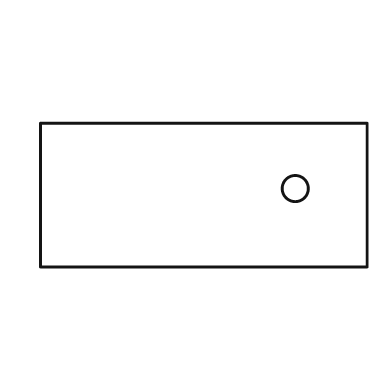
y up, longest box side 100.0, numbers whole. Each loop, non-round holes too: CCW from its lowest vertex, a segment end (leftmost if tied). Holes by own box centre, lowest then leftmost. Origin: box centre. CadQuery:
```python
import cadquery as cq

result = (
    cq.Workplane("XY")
    .moveTo(-50.0, -22.0)
    .lineTo(50.0, -22.0)
    .lineTo(50.0, 22.0)
    .lineTo(-50.0, 22.0)
    .close()
    .moveTo(28.0, 2.0)
    .circle(4.0)
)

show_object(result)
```